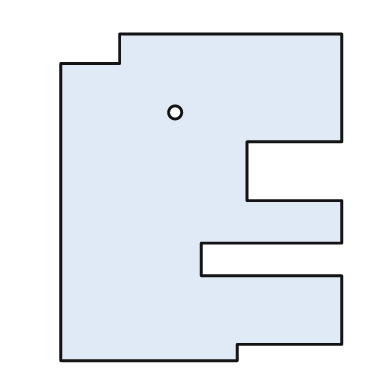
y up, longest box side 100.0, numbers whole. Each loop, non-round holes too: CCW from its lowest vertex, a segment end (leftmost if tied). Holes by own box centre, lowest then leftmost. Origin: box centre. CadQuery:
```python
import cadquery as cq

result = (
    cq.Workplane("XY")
    .moveTo(-43.0, -50.0)
    .lineTo(11.0, -50.0)
    .lineTo(11.0, -45.0)
    .lineTo(43.0, -45.0)
    .lineTo(43.0, -24.0)
    .lineTo(0.0, -24.0)
    .lineTo(0.0, -14.0)
    .lineTo(43.0, -14.0)
    .lineTo(43.0, -1.0)
    .lineTo(14.0, -1.0)
    .lineTo(14.0, 17.0)
    .lineTo(43.0, 17.0)
    .lineTo(43.0, 50.0)
    .lineTo(-25.0, 50.0)
    .lineTo(-25.0, 41.0)
    .lineTo(-43.0, 41.0)
    .close()
    .moveTo(-8.0, 26.0)
    .circle(2.0)
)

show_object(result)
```